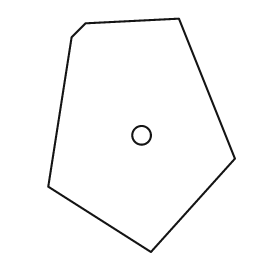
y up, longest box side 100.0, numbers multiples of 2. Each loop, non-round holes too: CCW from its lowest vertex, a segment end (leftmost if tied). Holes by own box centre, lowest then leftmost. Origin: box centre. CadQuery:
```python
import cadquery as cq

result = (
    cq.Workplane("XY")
    .moveTo(4.0, -50.0)
    .lineTo(40.0, -10.0)
    .lineTo(16.0, 50.0)
    .lineTo(-24.0, 48.0)
    .lineTo(-30.0, 42.0)
    .lineTo(-40.0, -22.0)
    .close()
    .moveTo(0.0, 0.0)
    .circle(4.0)
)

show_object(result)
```